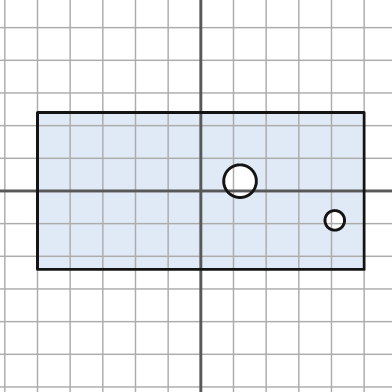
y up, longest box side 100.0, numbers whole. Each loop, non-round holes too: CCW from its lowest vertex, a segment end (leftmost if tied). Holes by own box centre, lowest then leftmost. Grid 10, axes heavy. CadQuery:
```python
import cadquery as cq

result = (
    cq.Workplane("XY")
    .moveTo(-50.0, -24.0)
    .lineTo(50.0, -24.0)
    .lineTo(50.0, 24.0)
    .lineTo(-50.0, 24.0)
    .close()
    .moveTo(41.0, -9.0)
    .circle(3.0)
    .moveTo(12.0, 3.0)
    .circle(5.0)
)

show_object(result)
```